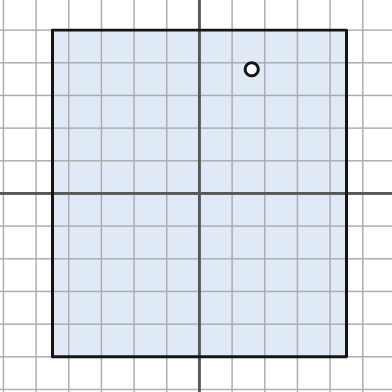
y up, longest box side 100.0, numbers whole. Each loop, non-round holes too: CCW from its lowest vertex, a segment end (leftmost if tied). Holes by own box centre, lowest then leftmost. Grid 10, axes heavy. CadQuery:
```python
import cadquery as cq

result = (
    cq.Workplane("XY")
    .moveTo(-45.0, -50.0)
    .lineTo(45.0, -50.0)
    .lineTo(45.0, 50.0)
    .lineTo(-45.0, 50.0)
    .close()
    .moveTo(16.0, 38.0)
    .circle(2.0)
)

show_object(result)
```